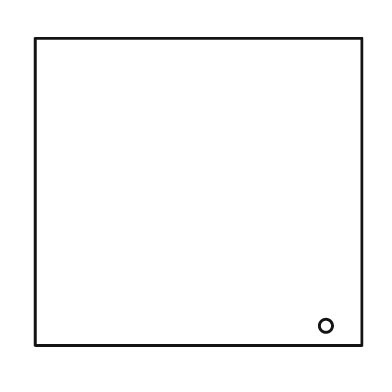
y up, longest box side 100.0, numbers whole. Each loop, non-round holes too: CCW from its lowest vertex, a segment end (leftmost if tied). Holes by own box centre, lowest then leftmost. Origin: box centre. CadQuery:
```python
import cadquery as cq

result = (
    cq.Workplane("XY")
    .moveTo(-50.0, -47.0)
    .lineTo(50.0, -47.0)
    .lineTo(50.0, 47.0)
    .lineTo(-50.0, 47.0)
    .close()
    .moveTo(39.0, -41.0)
    .circle(2.0)
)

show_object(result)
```